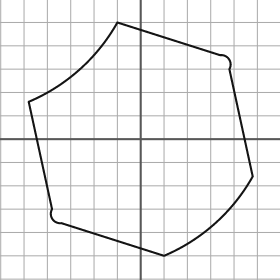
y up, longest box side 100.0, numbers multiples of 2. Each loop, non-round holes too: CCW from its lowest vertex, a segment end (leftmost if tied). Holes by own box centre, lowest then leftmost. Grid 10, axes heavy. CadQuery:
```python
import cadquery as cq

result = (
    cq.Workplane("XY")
    .moveTo(10.0, -50.0)
    .threePointArc((32.0, -36.0), (48.0, -16.0))
    .lineTo(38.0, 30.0)
    .threePointArc((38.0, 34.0), (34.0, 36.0))
    .lineTo(-10.0, 50.0)
    .threePointArc((-26.0, 30.0), (-48.0, 16.0))
    .lineTo(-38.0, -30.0)
    .threePointArc((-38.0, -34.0), (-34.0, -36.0))
    .close()
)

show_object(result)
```